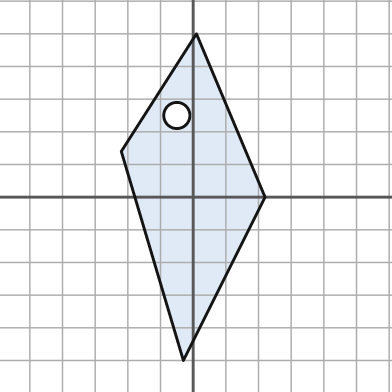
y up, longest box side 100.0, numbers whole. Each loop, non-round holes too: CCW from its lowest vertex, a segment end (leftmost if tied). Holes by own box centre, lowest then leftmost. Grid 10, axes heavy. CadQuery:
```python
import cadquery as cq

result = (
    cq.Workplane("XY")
    .moveTo(-3.0, -50.0)
    .lineTo(22.0, 0.0)
    .lineTo(1.0, 50.0)
    .lineTo(-22.0, 14.0)
    .close()
    .moveTo(-5.0, 25.0)
    .circle(4.0)
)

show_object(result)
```